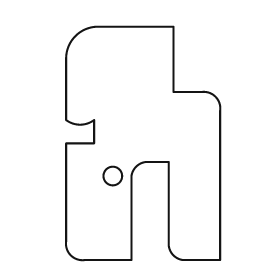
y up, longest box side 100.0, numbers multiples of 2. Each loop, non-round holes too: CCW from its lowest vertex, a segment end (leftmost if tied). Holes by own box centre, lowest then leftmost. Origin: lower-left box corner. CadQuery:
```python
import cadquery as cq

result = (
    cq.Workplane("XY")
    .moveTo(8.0, 0.0)
    .lineTo(28.0, 0.0)
    .lineTo(28.0, 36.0)
    .threePointArc((30.0, 40.0), (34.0, 42.0))
    .lineTo(44.0, 42.0)
    .lineTo(44.0, 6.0)
    .threePointArc((46.0, 2.0), (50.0, 0.0))
    .lineTo(66.0, 0.0)
    .lineTo(66.0, 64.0)
    .threePointArc((64.0, 70.0), (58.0, 72.0))
    .lineTo(46.0, 72.0)
    .lineTo(46.0, 100.0)
    .lineTo(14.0, 100.0)
    .threePointArc((4.0, 96.0), (0.0, 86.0))
    .lineTo(0.0, 60.0)
    .threePointArc((6.0, 58.0), (12.0, 60.0))
    .lineTo(12.0, 50.0)
    .lineTo(0.0, 50.0)
    .lineTo(0.0, 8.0)
    .threePointArc((2.0, 2.0), (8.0, 0.0))
    .close()
    .moveTo(20.0, 36.0)
    .circle(4.0)
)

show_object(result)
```